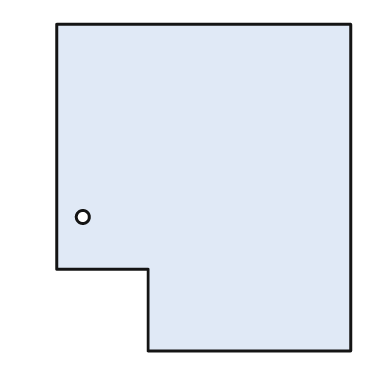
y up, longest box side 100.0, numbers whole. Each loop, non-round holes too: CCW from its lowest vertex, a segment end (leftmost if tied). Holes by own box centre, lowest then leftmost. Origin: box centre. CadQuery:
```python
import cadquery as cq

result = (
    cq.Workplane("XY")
    .moveTo(-17.0, -50.0)
    .lineTo(45.0, -50.0)
    .lineTo(45.0, 50.0)
    .lineTo(-45.0, 50.0)
    .lineTo(-45.0, -25.0)
    .lineTo(-17.0, -25.0)
    .close()
    .moveTo(-37.0, -9.0)
    .circle(2.0)
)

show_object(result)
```